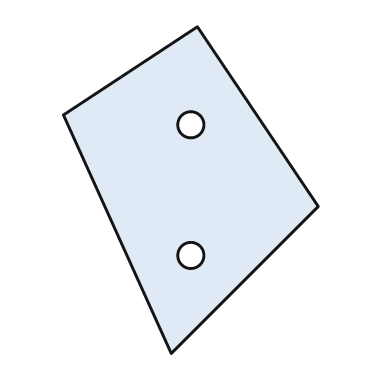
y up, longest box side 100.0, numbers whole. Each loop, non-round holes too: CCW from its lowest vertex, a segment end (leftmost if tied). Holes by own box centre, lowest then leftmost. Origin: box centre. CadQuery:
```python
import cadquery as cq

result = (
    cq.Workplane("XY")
    .moveTo(-6.0, -50.0)
    .lineTo(39.0, -5.0)
    .lineTo(2.0, 50.0)
    .lineTo(-39.0, 23.0)
    .close()
    .moveTo(0.0, -20.0)
    .circle(4.0)
    .moveTo(0.0, 20.0)
    .circle(4.0)
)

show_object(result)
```